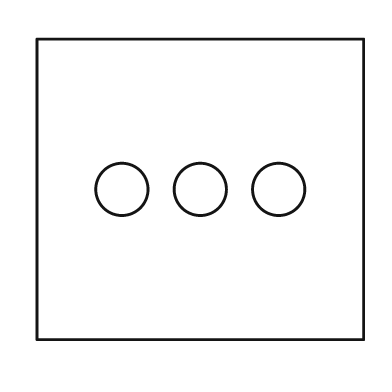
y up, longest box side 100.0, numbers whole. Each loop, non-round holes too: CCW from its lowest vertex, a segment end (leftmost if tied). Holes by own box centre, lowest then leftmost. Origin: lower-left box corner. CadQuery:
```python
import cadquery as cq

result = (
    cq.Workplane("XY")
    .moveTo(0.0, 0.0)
    .lineTo(100.0, 0.0)
    .lineTo(100.0, 92.0)
    .lineTo(0.0, 92.0)
    .close()
    .moveTo(26.0, 46.0)
    .circle(8.0)
    .moveTo(50.0, 46.0)
    .circle(8.0)
    .moveTo(74.0, 46.0)
    .circle(8.0)
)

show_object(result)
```